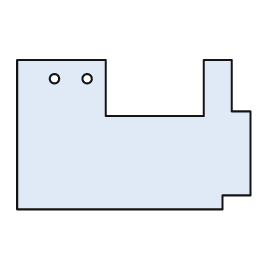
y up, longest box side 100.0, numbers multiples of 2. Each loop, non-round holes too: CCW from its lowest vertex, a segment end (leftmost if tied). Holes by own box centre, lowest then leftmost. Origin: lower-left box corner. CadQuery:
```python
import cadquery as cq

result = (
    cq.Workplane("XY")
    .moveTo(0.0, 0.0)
    .lineTo(88.0, 0.0)
    .lineTo(88.0, 6.0)
    .lineTo(100.0, 6.0)
    .lineTo(100.0, 42.0)
    .lineTo(92.0, 42.0)
    .lineTo(92.0, 64.0)
    .lineTo(80.0, 64.0)
    .lineTo(80.0, 40.0)
    .lineTo(38.0, 40.0)
    .lineTo(38.0, 64.0)
    .lineTo(0.0, 64.0)
    .close()
    .moveTo(16.0, 56.0)
    .circle(2.0)
    .moveTo(30.0, 56.0)
    .circle(2.0)
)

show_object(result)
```